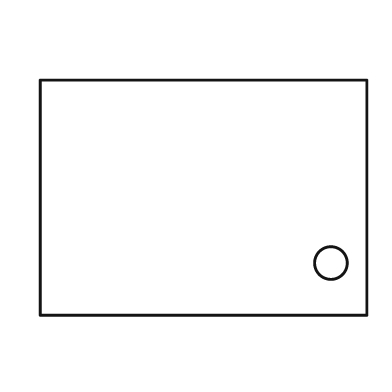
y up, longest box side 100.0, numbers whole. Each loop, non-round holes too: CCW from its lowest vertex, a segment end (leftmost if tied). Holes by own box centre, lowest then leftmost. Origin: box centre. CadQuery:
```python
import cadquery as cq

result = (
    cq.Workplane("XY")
    .moveTo(-50.0, -36.0)
    .lineTo(50.0, -36.0)
    .lineTo(50.0, 36.0)
    .lineTo(-50.0, 36.0)
    .close()
    .moveTo(39.0, -20.0)
    .circle(5.0)
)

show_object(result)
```